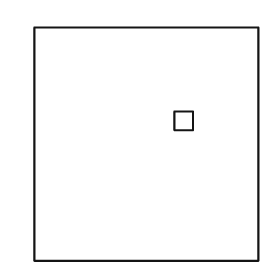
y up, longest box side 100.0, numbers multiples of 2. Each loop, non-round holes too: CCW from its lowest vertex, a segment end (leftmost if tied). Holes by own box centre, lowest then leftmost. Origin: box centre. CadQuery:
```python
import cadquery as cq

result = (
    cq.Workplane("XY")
    .moveTo(-48.0, -50.0)
    .lineTo(48.0, -50.0)
    .lineTo(48.0, 50.0)
    .lineTo(-48.0, 50.0)
    .close()
    .moveTo(12.0, 6.0)
    .lineTo(20.0, 6.0)
    .lineTo(20.0, 14.0)
    .lineTo(12.0, 14.0)
    .close()
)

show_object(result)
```